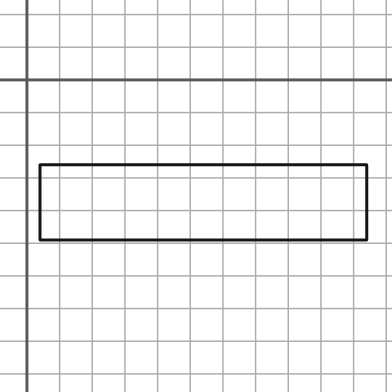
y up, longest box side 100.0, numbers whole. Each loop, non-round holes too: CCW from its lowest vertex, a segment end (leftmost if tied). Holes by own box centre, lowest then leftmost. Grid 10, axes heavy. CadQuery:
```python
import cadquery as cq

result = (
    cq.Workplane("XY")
    .moveTo(4.0, -49.0)
    .lineTo(104.0, -49.0)
    .lineTo(104.0, -26.0)
    .lineTo(4.0, -26.0)
    .close()
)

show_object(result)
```